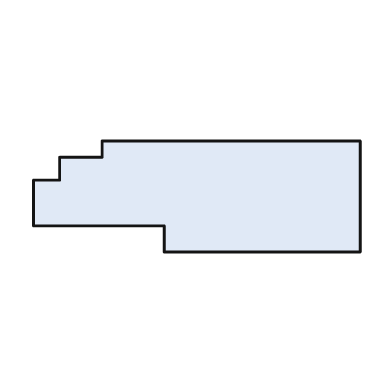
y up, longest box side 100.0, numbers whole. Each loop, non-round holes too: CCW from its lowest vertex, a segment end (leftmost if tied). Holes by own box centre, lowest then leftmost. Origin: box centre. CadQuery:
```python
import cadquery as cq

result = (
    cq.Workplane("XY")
    .moveTo(-10.0, -17.0)
    .lineTo(50.0, -17.0)
    .lineTo(50.0, 17.0)
    .lineTo(-29.0, 17.0)
    .lineTo(-29.0, 12.0)
    .lineTo(-42.0, 12.0)
    .lineTo(-42.0, 5.0)
    .lineTo(-50.0, 5.0)
    .lineTo(-50.0, -9.0)
    .lineTo(-10.0, -9.0)
    .close()
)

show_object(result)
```